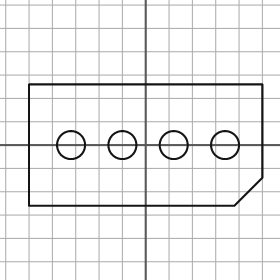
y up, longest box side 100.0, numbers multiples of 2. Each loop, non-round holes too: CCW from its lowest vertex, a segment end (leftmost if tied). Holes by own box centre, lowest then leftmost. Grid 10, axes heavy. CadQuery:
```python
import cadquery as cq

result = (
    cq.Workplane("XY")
    .moveTo(-50.0, -26.0)
    .lineTo(38.0, -26.0)
    .lineTo(50.0, -14.0)
    .lineTo(50.0, 26.0)
    .lineTo(-50.0, 26.0)
    .close()
    .moveTo(-32.0, 0.0)
    .circle(6.0)
    .moveTo(-10.0, 0.0)
    .circle(6.0)
    .moveTo(12.0, 0.0)
    .circle(6.0)
    .moveTo(34.0, 0.0)
    .circle(6.0)
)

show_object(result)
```